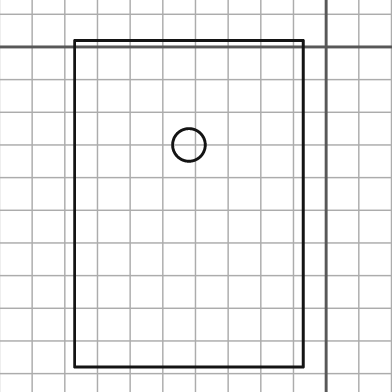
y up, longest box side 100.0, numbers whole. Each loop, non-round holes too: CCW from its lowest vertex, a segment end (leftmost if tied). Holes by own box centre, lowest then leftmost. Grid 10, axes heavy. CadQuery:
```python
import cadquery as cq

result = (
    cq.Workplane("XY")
    .moveTo(-77.0, -98.0)
    .lineTo(-7.0, -98.0)
    .lineTo(-7.0, 2.0)
    .lineTo(-77.0, 2.0)
    .close()
    .moveTo(-42.0, -30.0)
    .circle(5.0)
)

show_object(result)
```